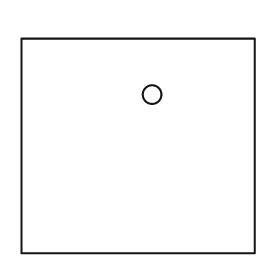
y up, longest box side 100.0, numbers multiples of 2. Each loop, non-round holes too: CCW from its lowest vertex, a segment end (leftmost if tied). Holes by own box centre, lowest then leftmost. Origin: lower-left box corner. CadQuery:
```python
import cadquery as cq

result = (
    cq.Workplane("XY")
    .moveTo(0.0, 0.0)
    .lineTo(100.0, 0.0)
    .lineTo(100.0, 92.0)
    .lineTo(0.0, 92.0)
    .close()
    .moveTo(56.0, 68.0)
    .circle(4.0)
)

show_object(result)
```